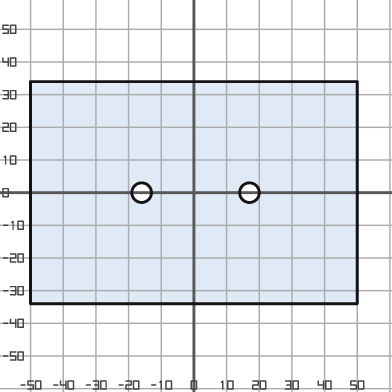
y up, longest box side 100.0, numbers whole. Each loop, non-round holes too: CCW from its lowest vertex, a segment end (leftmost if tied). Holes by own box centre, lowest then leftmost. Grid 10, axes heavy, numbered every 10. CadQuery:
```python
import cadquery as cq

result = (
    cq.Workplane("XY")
    .moveTo(-50.0, -34.0)
    .lineTo(50.0, -34.0)
    .lineTo(50.0, 34.0)
    .lineTo(-50.0, 34.0)
    .close()
    .moveTo(-16.0, 0.0)
    .circle(3.0)
    .moveTo(17.0, 0.0)
    .circle(3.0)
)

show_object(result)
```